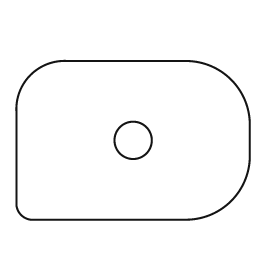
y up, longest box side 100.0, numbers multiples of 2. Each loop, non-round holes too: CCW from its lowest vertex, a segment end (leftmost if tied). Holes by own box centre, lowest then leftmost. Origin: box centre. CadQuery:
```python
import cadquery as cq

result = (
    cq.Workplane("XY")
    .moveTo(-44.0, -34.0)
    .lineTo(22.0, -34.0)
    .threePointArc((42.0, -26.0), (50.0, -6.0))
    .lineTo(50.0, 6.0)
    .threePointArc((42.0, 26.0), (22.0, 34.0))
    .lineTo(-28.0, 34.0)
    .threePointArc((-44.0, 28.0), (-50.0, 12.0))
    .lineTo(-50.0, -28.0)
    .threePointArc((-48.0, -32.0), (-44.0, -34.0))
    .close()
    .moveTo(0.0, 0.0)
    .circle(8.0)
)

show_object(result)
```